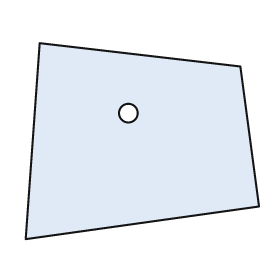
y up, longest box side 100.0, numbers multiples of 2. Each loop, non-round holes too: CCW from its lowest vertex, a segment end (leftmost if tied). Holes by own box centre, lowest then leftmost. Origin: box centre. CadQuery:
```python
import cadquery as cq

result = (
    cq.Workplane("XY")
    .moveTo(-50.0, -42.0)
    .lineTo(50.0, -28.0)
    .lineTo(42.0, 32.0)
    .lineTo(-44.0, 42.0)
    .close()
    .moveTo(-6.0, 12.0)
    .circle(4.0)
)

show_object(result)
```